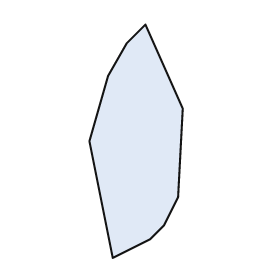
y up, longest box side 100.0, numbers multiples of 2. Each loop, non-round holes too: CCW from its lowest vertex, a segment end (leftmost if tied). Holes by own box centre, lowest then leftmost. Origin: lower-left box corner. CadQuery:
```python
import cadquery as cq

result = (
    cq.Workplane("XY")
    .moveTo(10.0, 0.0)
    .lineTo(26.0, 8.0)
    .lineTo(32.0, 14.0)
    .lineTo(38.0, 26.0)
    .lineTo(40.0, 64.0)
    .lineTo(24.0, 100.0)
    .lineTo(16.0, 92.0)
    .lineTo(8.0, 78.0)
    .lineTo(0.0, 50.0)
    .close()
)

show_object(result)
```